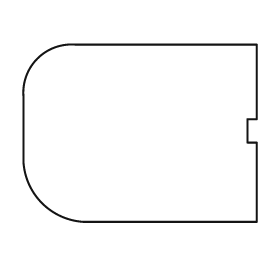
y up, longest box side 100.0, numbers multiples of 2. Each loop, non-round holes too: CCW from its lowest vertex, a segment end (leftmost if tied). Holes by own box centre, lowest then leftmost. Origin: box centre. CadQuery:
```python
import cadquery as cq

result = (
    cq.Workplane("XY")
    .moveTo(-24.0, -38.0)
    .lineTo(50.0, -38.0)
    .lineTo(50.0, -4.0)
    .lineTo(46.0, -4.0)
    .lineTo(46.0, 6.0)
    .lineTo(50.0, 6.0)
    .lineTo(50.0, 38.0)
    .lineTo(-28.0, 38.0)
    .threePointArc((-44.0, 32.0), (-50.0, 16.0))
    .lineTo(-50.0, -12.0)
    .threePointArc((-42.0, -30.0), (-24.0, -38.0))
    .close()
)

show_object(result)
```